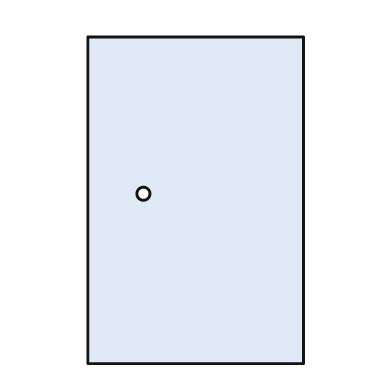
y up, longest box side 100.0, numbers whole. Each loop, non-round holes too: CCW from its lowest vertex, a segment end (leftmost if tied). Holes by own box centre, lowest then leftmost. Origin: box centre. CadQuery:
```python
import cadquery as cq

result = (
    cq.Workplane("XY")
    .moveTo(-33.0, -50.0)
    .lineTo(33.0, -50.0)
    .lineTo(33.0, 50.0)
    .lineTo(-33.0, 50.0)
    .close()
    .moveTo(-16.0, 2.0)
    .circle(2.0)
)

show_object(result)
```